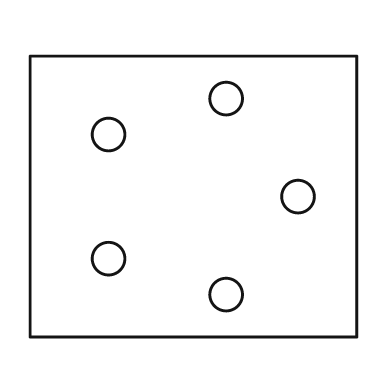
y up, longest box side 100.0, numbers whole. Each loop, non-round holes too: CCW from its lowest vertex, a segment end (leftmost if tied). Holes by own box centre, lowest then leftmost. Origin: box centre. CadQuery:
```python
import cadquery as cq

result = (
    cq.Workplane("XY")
    .moveTo(-50.0, -43.0)
    .lineTo(50.0, -43.0)
    .lineTo(50.0, 43.0)
    .lineTo(-50.0, 43.0)
    .close()
    .moveTo(10.0, -30.0)
    .circle(5.0)
    .moveTo(-26.0, -19.0)
    .circle(5.0)
    .moveTo(32.0, 0.0)
    .circle(5.0)
    .moveTo(-26.0, 19.0)
    .circle(5.0)
    .moveTo(10.0, 30.0)
    .circle(5.0)
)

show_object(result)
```